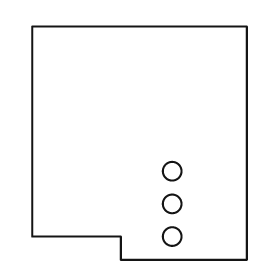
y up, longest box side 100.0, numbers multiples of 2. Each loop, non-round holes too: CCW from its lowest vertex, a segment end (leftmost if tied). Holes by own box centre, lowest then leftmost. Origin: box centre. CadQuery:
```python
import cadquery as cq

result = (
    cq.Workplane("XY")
    .moveTo(-8.0, -50.0)
    .lineTo(46.0, -50.0)
    .lineTo(46.0, 50.0)
    .lineTo(-46.0, 50.0)
    .lineTo(-46.0, -40.0)
    .lineTo(-8.0, -40.0)
    .close()
    .moveTo(14.0, -40.0)
    .circle(4.0)
    .moveTo(14.0, -26.0)
    .circle(4.0)
    .moveTo(14.0, -12.0)
    .circle(4.0)
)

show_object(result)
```